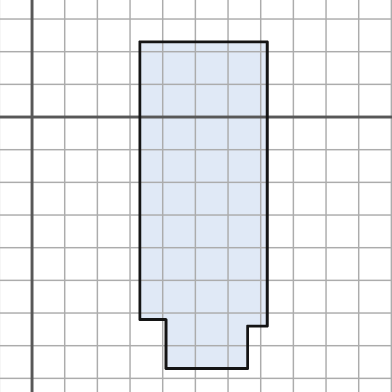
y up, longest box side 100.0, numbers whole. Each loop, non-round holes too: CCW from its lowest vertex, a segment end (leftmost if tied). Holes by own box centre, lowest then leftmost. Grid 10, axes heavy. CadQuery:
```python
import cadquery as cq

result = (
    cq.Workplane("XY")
    .moveTo(41.0, -77.0)
    .lineTo(66.0, -77.0)
    .lineTo(66.0, -64.0)
    .lineTo(72.0, -64.0)
    .lineTo(72.0, 23.0)
    .lineTo(33.0, 23.0)
    .lineTo(33.0, -62.0)
    .lineTo(41.0, -62.0)
    .close()
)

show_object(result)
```